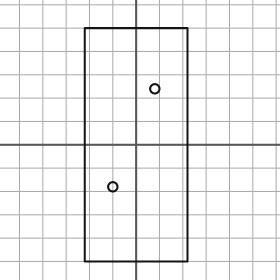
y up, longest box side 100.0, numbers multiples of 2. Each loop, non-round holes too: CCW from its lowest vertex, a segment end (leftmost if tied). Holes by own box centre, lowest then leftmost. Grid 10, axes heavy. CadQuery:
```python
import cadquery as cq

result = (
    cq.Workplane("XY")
    .moveTo(-22.0, -50.0)
    .lineTo(22.0, -50.0)
    .lineTo(22.0, 50.0)
    .lineTo(-22.0, 50.0)
    .close()
    .moveTo(-10.0, -18.0)
    .circle(2.0)
    .moveTo(8.0, 24.0)
    .circle(2.0)
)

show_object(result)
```